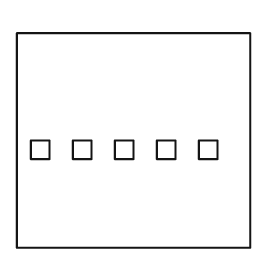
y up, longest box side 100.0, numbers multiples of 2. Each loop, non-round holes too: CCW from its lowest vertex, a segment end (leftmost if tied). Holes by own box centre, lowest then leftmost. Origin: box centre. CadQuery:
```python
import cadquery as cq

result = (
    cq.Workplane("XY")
    .moveTo(-50.0, -46.0)
    .lineTo(50.0, -46.0)
    .lineTo(50.0, 46.0)
    .lineTo(-50.0, 46.0)
    .close()
    .moveTo(-44.0, -8.0)
    .lineTo(-36.0, -8.0)
    .lineTo(-36.0, 0.0)
    .lineTo(-44.0, 0.0)
    .close()
    .moveTo(-26.0, -8.0)
    .lineTo(-18.0, -8.0)
    .lineTo(-18.0, 0.0)
    .lineTo(-26.0, 0.0)
    .close()
    .moveTo(-8.0, -8.0)
    .lineTo(0.0, -8.0)
    .lineTo(0.0, 0.0)
    .lineTo(-8.0, 0.0)
    .close()
    .moveTo(10.0, -8.0)
    .lineTo(18.0, -8.0)
    .lineTo(18.0, 0.0)
    .lineTo(10.0, 0.0)
    .close()
    .moveTo(28.0, -8.0)
    .lineTo(36.0, -8.0)
    .lineTo(36.0, 0.0)
    .lineTo(28.0, 0.0)
    .close()
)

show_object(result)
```